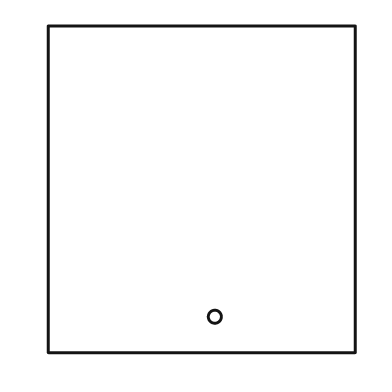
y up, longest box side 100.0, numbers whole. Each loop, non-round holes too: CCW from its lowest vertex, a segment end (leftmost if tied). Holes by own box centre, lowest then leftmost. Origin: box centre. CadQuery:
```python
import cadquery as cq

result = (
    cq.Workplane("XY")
    .moveTo(-47.0, -50.0)
    .lineTo(47.0, -50.0)
    .lineTo(47.0, 50.0)
    .lineTo(-47.0, 50.0)
    .close()
    .moveTo(4.0, -39.0)
    .circle(2.0)
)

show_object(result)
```